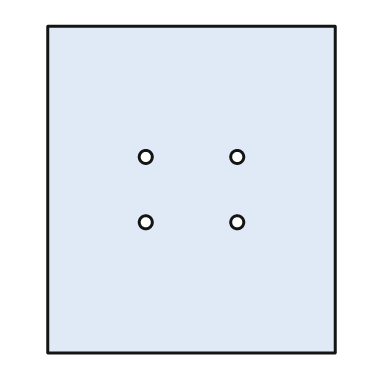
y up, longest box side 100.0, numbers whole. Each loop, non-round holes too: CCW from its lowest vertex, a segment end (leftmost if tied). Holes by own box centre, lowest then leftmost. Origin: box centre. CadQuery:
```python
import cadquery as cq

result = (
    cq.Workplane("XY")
    .moveTo(-44.0, -50.0)
    .lineTo(44.0, -50.0)
    .lineTo(44.0, 50.0)
    .lineTo(-44.0, 50.0)
    .close()
    .moveTo(-14.0, -10.0)
    .circle(2.0)
    .moveTo(14.0, -10.0)
    .circle(2.0)
    .moveTo(-14.0, 10.0)
    .circle(2.0)
    .moveTo(14.0, 10.0)
    .circle(2.0)
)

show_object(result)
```